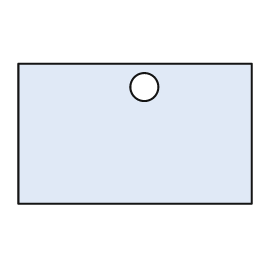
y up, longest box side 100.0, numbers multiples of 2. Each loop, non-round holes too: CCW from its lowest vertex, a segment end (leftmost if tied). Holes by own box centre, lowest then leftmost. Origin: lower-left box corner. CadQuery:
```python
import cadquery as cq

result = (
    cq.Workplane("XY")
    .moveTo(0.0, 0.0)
    .lineTo(100.0, 0.0)
    .lineTo(100.0, 60.0)
    .lineTo(0.0, 60.0)
    .close()
    .moveTo(54.0, 50.0)
    .circle(6.0)
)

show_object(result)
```